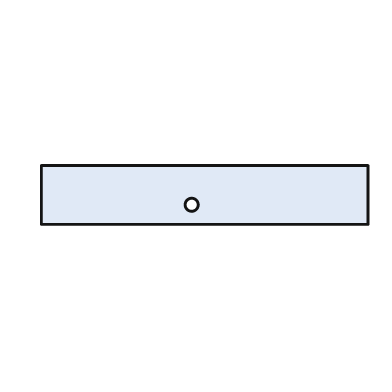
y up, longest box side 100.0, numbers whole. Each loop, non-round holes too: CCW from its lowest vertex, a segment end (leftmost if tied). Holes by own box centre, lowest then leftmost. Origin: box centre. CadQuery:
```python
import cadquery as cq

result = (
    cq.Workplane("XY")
    .moveTo(-50.0, -9.0)
    .lineTo(50.0, -9.0)
    .lineTo(50.0, 9.0)
    .lineTo(-50.0, 9.0)
    .close()
    .moveTo(-4.0, -3.0)
    .circle(2.0)
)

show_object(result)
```